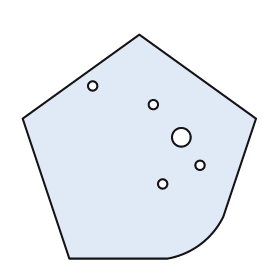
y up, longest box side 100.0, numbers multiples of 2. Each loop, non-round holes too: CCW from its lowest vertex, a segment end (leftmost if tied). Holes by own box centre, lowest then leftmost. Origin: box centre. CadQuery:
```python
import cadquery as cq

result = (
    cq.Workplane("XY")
    .moveTo(-30.0, -48.0)
    .lineTo(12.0, -48.0)
    .threePointArc((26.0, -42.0), (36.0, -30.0))
    .lineTo(50.0, 12.0)
    .lineTo(0.0, 48.0)
    .lineTo(-50.0, 12.0)
    .close()
    .moveTo(10.0, -16.0)
    .circle(2.0)
    .moveTo(26.0, -8.0)
    .circle(2.0)
    .moveTo(18.0, 4.0)
    .circle(4.0)
    .moveTo(6.0, 18.0)
    .circle(2.0)
    .moveTo(-20.0, 26.0)
    .circle(2.0)
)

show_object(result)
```